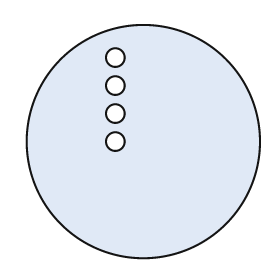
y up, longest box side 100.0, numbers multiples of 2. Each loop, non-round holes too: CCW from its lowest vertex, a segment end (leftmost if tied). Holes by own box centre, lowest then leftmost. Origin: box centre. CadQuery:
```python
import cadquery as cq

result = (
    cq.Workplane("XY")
    .moveTo(0.0, 0.0)
    .circle(50.0)
    .moveTo(-12.0, 0.0)
    .circle(4.0)
    .moveTo(-12.0, 12.0)
    .circle(4.0)
    .moveTo(-12.0, 24.0)
    .circle(4.0)
    .moveTo(-12.0, 36.0)
    .circle(4.0)
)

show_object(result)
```